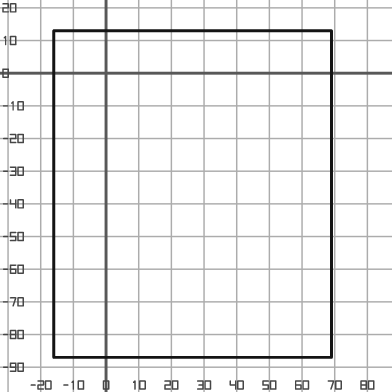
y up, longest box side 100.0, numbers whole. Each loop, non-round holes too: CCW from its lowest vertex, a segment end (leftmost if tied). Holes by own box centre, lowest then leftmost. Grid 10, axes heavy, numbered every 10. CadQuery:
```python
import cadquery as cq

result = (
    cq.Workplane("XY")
    .moveTo(-16.0, -87.0)
    .lineTo(69.0, -87.0)
    .lineTo(69.0, 13.0)
    .lineTo(-16.0, 13.0)
    .close()
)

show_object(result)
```